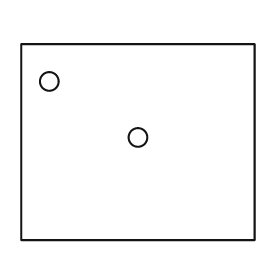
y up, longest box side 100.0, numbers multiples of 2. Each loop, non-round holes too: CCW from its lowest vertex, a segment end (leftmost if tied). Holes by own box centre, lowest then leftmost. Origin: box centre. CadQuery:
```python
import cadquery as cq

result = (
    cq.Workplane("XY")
    .moveTo(-50.0, -42.0)
    .lineTo(50.0, -42.0)
    .lineTo(50.0, 42.0)
    .lineTo(-50.0, 42.0)
    .close()
    .moveTo(0.0, 2.0)
    .circle(4.0)
    .moveTo(-38.0, 26.0)
    .circle(4.0)
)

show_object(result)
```